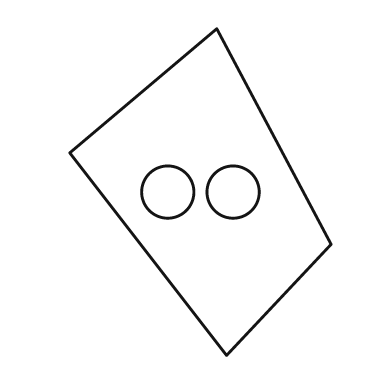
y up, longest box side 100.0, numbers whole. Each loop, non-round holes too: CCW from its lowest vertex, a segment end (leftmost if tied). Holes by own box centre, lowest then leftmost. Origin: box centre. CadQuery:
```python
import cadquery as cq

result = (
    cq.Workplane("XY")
    .moveTo(8.0, -50.0)
    .lineTo(40.0, -16.0)
    .lineTo(5.0, 50.0)
    .lineTo(-40.0, 12.0)
    .close()
    .moveTo(-10.0, 0.0)
    .circle(8.0)
    .moveTo(10.0, 0.0)
    .circle(8.0)
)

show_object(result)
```